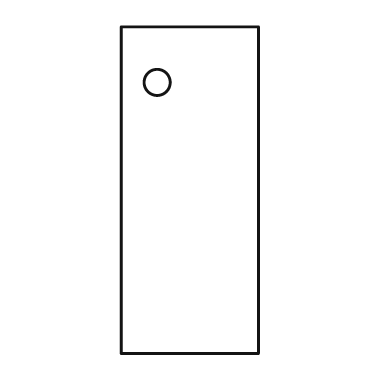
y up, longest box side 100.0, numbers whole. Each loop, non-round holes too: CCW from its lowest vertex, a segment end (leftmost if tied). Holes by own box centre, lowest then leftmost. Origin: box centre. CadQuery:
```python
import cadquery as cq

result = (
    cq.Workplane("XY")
    .moveTo(-21.0, -50.0)
    .lineTo(21.0, -50.0)
    .lineTo(21.0, 50.0)
    .lineTo(-21.0, 50.0)
    .close()
    .moveTo(-10.0, 33.0)
    .circle(4.0)
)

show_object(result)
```